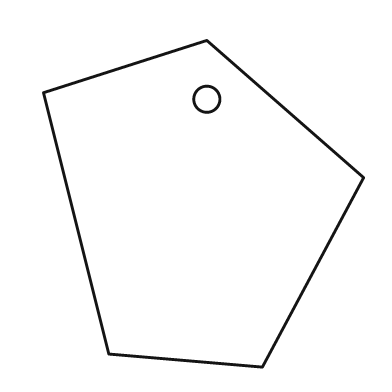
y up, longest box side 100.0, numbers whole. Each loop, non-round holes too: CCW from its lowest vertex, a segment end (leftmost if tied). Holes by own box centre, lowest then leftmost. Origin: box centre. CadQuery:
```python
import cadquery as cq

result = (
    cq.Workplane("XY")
    .moveTo(18.0, -50.0)
    .lineTo(49.0, 8.0)
    .lineTo(1.0, 50.0)
    .lineTo(-49.0, 34.0)
    .lineTo(-29.0, -46.0)
    .close()
    .moveTo(1.0, 32.0)
    .circle(4.0)
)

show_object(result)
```